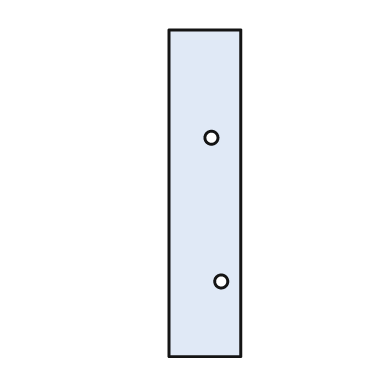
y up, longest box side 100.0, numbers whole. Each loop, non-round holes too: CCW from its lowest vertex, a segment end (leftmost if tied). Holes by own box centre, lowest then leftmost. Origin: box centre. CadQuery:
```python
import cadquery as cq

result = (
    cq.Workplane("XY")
    .moveTo(-11.0, -50.0)
    .lineTo(11.0, -50.0)
    .lineTo(11.0, 50.0)
    .lineTo(-11.0, 50.0)
    .close()
    .moveTo(5.0, -27.0)
    .circle(2.0)
    .moveTo(2.0, 17.0)
    .circle(2.0)
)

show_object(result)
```